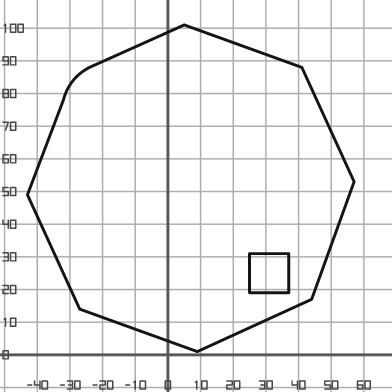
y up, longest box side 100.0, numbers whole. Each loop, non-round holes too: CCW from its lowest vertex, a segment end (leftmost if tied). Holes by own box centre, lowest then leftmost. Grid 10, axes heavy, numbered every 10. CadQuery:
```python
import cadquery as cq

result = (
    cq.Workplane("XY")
    .moveTo(9.0, 1.0)
    .lineTo(44.0, 17.0)
    .lineTo(57.0, 53.0)
    .lineTo(41.0, 88.0)
    .lineTo(5.0, 101.0)
    .lineTo(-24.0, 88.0)
    .threePointArc((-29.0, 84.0), (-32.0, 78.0))
    .lineTo(-43.0, 49.0)
    .lineTo(-27.0, 14.0)
    .close()
    .moveTo(25.0, 19.0)
    .lineTo(37.0, 19.0)
    .lineTo(37.0, 31.0)
    .lineTo(25.0, 31.0)
    .close()
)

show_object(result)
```